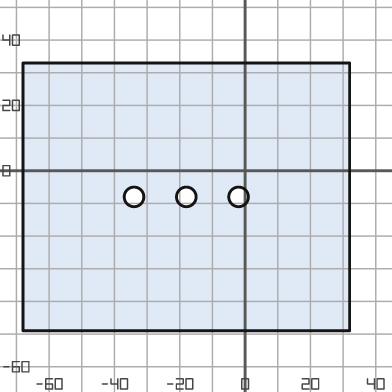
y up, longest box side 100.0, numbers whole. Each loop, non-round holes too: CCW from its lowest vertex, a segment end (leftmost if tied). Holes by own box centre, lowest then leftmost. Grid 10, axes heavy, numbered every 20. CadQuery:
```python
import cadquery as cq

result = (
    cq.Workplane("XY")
    .moveTo(-68.0, -49.0)
    .lineTo(32.0, -49.0)
    .lineTo(32.0, 33.0)
    .lineTo(-68.0, 33.0)
    .close()
    .moveTo(-34.0, -8.0)
    .circle(3.0)
    .moveTo(-18.0, -8.0)
    .circle(3.0)
    .moveTo(-2.0, -8.0)
    .circle(3.0)
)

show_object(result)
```